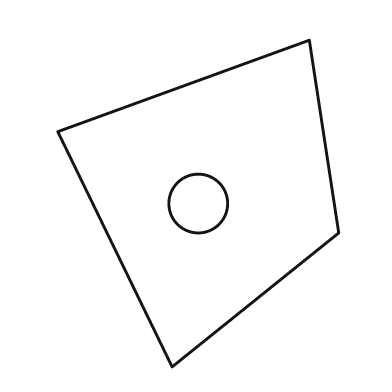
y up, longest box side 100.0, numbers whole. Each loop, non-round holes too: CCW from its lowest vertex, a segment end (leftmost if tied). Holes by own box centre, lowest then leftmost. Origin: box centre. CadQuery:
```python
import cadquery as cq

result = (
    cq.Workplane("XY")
    .moveTo(-8.0, -50.0)
    .lineTo(43.0, -9.0)
    .lineTo(34.0, 50.0)
    .lineTo(-43.0, 22.0)
    .close()
    .moveTo(0.0, 0.0)
    .circle(9.0)
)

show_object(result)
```